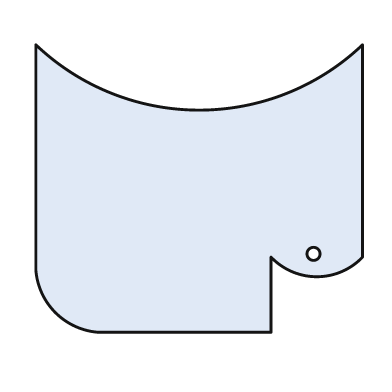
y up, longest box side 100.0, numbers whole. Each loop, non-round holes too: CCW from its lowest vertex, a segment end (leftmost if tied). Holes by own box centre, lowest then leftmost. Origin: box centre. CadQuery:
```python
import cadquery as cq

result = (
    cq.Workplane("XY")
    .moveTo(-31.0, -44.0)
    .lineTo(22.0, -44.0)
    .lineTo(22.0, -21.0)
    .threePointArc((36.0, -27.0), (50.0, -21.0))
    .lineTo(50.0, 44.0)
    .threePointArc((0.0, 24.0), (-50.0, 44.0))
    .lineTo(-50.0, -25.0)
    .threePointArc((-44.0, -38.0), (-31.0, -44.0))
    .close()
    .moveTo(35.0, -20.0)
    .circle(2.0)
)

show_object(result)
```